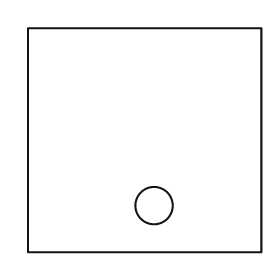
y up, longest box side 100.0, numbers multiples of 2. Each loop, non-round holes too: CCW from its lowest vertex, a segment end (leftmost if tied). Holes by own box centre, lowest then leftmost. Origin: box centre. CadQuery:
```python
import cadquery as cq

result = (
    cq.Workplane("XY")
    .moveTo(-50.0, -48.0)
    .lineTo(50.0, -48.0)
    .lineTo(50.0, 48.0)
    .lineTo(-50.0, 48.0)
    .close()
    .moveTo(4.0, -28.0)
    .circle(8.0)
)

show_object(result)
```